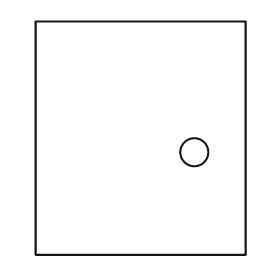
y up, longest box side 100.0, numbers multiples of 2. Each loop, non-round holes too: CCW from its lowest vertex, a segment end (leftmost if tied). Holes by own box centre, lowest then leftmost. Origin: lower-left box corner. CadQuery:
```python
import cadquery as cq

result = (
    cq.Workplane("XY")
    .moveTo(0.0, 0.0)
    .lineTo(90.0, 0.0)
    .lineTo(90.0, 100.0)
    .lineTo(0.0, 100.0)
    .close()
    .moveTo(68.0, 44.0)
    .circle(6.0)
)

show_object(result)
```